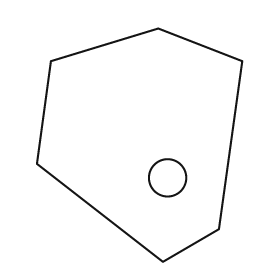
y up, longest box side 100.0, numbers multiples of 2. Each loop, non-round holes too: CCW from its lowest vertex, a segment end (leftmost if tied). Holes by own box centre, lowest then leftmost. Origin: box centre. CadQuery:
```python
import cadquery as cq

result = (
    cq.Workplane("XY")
    .moveTo(10.0, -50.0)
    .lineTo(34.0, -36.0)
    .lineTo(44.0, 36.0)
    .lineTo(8.0, 50.0)
    .lineTo(-38.0, 36.0)
    .lineTo(-44.0, -8.0)
    .close()
    .moveTo(12.0, -14.0)
    .circle(8.0)
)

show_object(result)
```